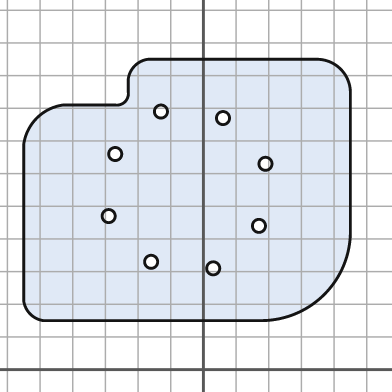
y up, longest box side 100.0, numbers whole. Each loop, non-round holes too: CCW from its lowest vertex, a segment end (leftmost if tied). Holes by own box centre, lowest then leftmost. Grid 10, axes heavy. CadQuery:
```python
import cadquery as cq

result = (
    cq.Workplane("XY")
    .moveTo(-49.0, 15.0)
    .lineTo(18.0, 15.0)
    .threePointArc((37.0, 23.0), (45.0, 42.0))
    .lineTo(45.0, 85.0)
    .threePointArc((42.0, 92.0), (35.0, 95.0))
    .lineTo(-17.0, 95.0)
    .threePointArc((-21.0, 93.0), (-23.0, 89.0))
    .lineTo(-23.0, 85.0)
    .threePointArc((-24.0, 82.0), (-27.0, 81.0))
    .lineTo(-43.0, 81.0)
    .threePointArc((-51.0, 77.0), (-55.0, 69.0))
    .lineTo(-55.0, 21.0)
    .threePointArc((-53.0, 17.0), (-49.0, 15.0))
    .close()
    .moveTo(3.0, 31.0)
    .circle(2.0)
    .moveTo(-16.0, 33.0)
    .circle(2.0)
    .moveTo(17.0, 44.0)
    .circle(2.0)
    .moveTo(-29.0, 47.0)
    .circle(2.0)
    .moveTo(19.0, 63.0)
    .circle(2.0)
    .moveTo(-27.0, 66.0)
    .circle(2.0)
    .moveTo(6.0, 77.0)
    .circle(2.0)
    .moveTo(-13.0, 79.0)
    .circle(2.0)
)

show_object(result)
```